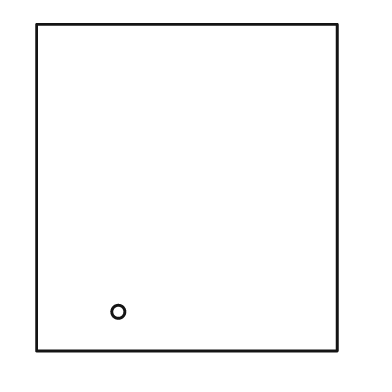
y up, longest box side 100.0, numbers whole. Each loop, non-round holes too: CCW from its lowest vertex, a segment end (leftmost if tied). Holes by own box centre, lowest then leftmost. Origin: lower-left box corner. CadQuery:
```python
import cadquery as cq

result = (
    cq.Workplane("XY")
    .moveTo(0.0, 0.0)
    .lineTo(92.0, 0.0)
    .lineTo(92.0, 100.0)
    .lineTo(0.0, 100.0)
    .close()
    .moveTo(25.0, 12.0)
    .circle(2.0)
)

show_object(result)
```